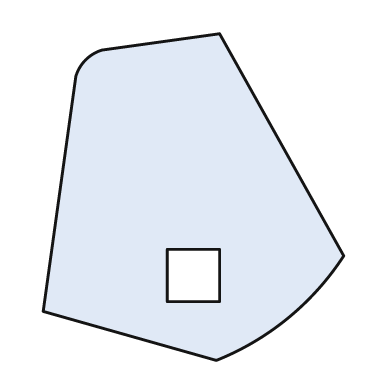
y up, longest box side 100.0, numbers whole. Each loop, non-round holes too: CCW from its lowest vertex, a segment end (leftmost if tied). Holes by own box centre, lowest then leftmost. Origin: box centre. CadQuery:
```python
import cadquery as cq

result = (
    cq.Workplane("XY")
    .moveTo(7.0, -50.0)
    .threePointArc((29.0, -37.0), (46.0, -18.0))
    .lineTo(8.0, 50.0)
    .lineTo(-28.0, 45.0)
    .threePointArc((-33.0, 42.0), (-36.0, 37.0))
    .lineTo(-46.0, -35.0)
    .close()
    .moveTo(-8.0, -32.0)
    .lineTo(8.0, -32.0)
    .lineTo(8.0, -16.0)
    .lineTo(-8.0, -16.0)
    .close()
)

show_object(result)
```